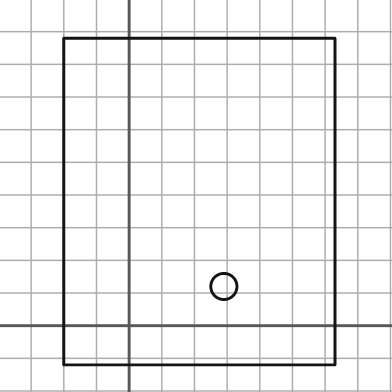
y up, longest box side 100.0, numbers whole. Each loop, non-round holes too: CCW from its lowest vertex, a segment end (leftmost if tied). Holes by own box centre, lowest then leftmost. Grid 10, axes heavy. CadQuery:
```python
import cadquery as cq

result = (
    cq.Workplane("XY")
    .moveTo(-20.0, -12.0)
    .lineTo(63.0, -12.0)
    .lineTo(63.0, 88.0)
    .lineTo(-20.0, 88.0)
    .close()
    .moveTo(29.0, 12.0)
    .circle(4.0)
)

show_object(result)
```